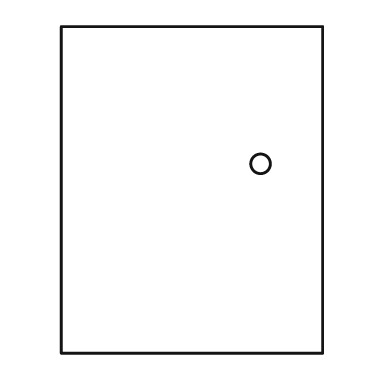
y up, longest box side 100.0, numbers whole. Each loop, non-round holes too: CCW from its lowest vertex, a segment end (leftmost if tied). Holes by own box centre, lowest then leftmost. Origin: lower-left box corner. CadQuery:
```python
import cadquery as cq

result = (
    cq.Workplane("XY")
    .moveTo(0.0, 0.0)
    .lineTo(80.0, 0.0)
    .lineTo(80.0, 100.0)
    .lineTo(0.0, 100.0)
    .close()
    .moveTo(61.0, 58.0)
    .circle(3.0)
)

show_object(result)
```